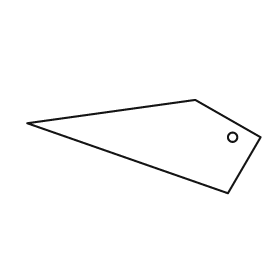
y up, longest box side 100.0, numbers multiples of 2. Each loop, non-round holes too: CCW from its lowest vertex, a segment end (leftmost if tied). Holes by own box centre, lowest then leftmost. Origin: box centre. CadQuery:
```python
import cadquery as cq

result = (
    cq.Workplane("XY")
    .moveTo(36.0, -20.0)
    .lineTo(50.0, 4.0)
    .lineTo(22.0, 20.0)
    .lineTo(-50.0, 10.0)
    .close()
    .moveTo(38.0, 4.0)
    .circle(2.0)
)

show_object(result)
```